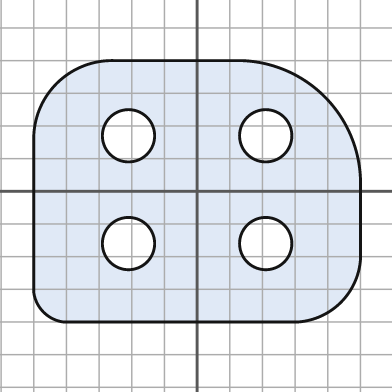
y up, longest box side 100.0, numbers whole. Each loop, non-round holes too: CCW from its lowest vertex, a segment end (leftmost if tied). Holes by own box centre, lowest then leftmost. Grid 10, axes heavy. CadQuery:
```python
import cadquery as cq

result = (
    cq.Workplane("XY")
    .moveTo(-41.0, -40.0)
    .lineTo(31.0, -40.0)
    .threePointArc((44.0, -34.0), (50.0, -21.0))
    .lineTo(50.0, 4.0)
    .threePointArc((39.0, 29.0), (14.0, 40.0))
    .lineTo(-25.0, 40.0)
    .threePointArc((-43.0, 33.0), (-50.0, 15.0))
    .lineTo(-50.0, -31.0)
    .threePointArc((-47.0, -37.0), (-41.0, -40.0))
    .close()
    .moveTo(-21.0, -16.0)
    .circle(8.0)
    .moveTo(21.0, -16.0)
    .circle(8.0)
    .moveTo(-21.0, 17.0)
    .circle(8.0)
    .moveTo(21.0, 17.0)
    .circle(8.0)
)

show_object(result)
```